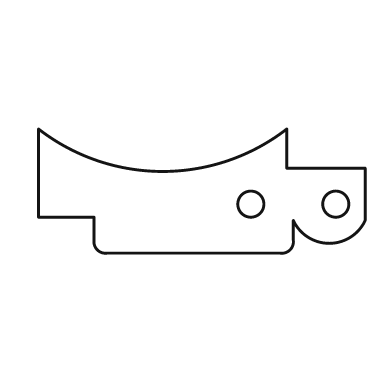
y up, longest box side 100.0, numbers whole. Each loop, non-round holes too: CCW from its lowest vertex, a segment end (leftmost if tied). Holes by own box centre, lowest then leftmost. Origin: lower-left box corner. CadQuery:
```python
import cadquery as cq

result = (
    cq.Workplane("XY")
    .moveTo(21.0, 0.0)
    .lineTo(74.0, 0.0)
    .threePointArc((77.0, 1.0), (78.0, 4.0))
    .lineTo(78.0, 10.0)
    .threePointArc((89.0, 3.0), (100.0, 10.0))
    .lineTo(100.0, 26.0)
    .lineTo(76.0, 26.0)
    .lineTo(76.0, 38.0)
    .threePointArc((38.0, 25.0), (0.0, 38.0))
    .lineTo(0.0, 11.0)
    .lineTo(17.0, 11.0)
    .lineTo(17.0, 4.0)
    .threePointArc((18.0, 1.0), (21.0, 0.0))
    .close()
    .moveTo(65.0, 15.0)
    .circle(4.0)
    .moveTo(91.0, 15.0)
    .circle(4.0)
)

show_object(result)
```